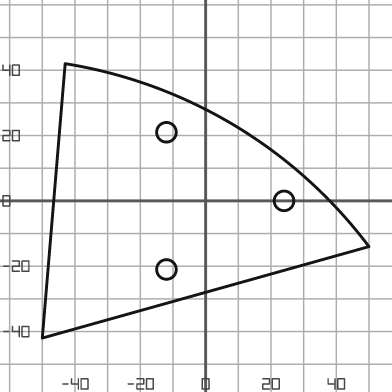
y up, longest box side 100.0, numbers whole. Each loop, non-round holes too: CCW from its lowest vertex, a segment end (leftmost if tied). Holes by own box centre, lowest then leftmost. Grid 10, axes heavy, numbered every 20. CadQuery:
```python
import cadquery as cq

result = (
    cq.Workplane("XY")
    .moveTo(-50.0, -42.0)
    .lineTo(50.0, -14.0)
    .threePointArc((9.0, 23.0), (-43.0, 42.0))
    .close()
    .moveTo(-12.0, -21.0)
    .circle(3.0)
    .moveTo(24.0, 0.0)
    .circle(3.0)
    .moveTo(-12.0, 21.0)
    .circle(3.0)
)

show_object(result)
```